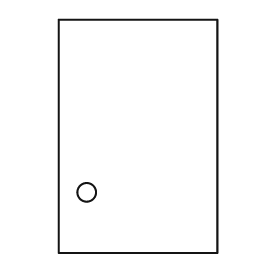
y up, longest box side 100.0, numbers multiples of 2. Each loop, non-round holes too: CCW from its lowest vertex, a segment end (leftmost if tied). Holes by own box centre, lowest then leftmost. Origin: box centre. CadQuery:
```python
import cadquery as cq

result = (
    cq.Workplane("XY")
    .moveTo(-34.0, -50.0)
    .lineTo(34.0, -50.0)
    .lineTo(34.0, 50.0)
    .lineTo(-34.0, 50.0)
    .close()
    .moveTo(-22.0, -24.0)
    .circle(4.0)
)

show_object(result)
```